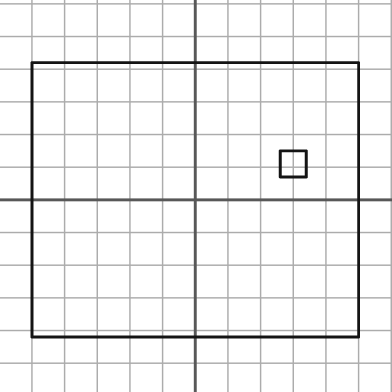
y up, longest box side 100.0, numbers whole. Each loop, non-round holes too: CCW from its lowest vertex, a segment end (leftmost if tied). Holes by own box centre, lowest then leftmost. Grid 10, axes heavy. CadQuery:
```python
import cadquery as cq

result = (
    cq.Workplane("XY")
    .moveTo(-50.0, -42.0)
    .lineTo(50.0, -42.0)
    .lineTo(50.0, 42.0)
    .lineTo(-50.0, 42.0)
    .close()
    .moveTo(26.0, 7.0)
    .lineTo(34.0, 7.0)
    .lineTo(34.0, 15.0)
    .lineTo(26.0, 15.0)
    .close()
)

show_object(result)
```